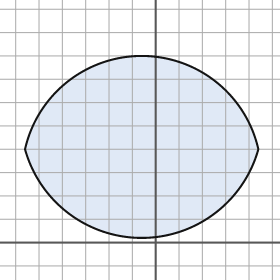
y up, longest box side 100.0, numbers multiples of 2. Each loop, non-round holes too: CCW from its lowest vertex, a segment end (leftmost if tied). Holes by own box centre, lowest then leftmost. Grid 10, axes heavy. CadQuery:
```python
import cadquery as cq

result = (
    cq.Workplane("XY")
    .moveTo(-56.0, 40.0)
    .threePointArc((-6.0, 2.0), (44.0, 40.0))
    .threePointArc((-6.0, 80.0), (-56.0, 40.0))
    .close()
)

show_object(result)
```